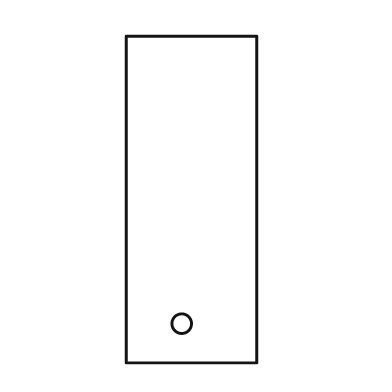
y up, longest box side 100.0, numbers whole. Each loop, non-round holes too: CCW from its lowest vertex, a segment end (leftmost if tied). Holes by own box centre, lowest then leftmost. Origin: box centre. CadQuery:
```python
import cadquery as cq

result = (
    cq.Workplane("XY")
    .moveTo(-20.0, -50.0)
    .lineTo(20.0, -50.0)
    .lineTo(20.0, 50.0)
    .lineTo(-20.0, 50.0)
    .close()
    .moveTo(-3.0, -38.0)
    .circle(3.0)
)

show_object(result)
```